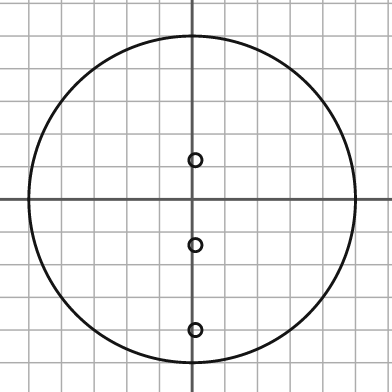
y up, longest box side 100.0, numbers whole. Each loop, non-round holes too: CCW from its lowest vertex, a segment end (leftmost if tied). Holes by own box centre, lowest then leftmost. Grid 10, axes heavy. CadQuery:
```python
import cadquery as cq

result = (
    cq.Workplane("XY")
    .moveTo(0.0, 0.0)
    .circle(50.0)
    .moveTo(1.0, -40.0)
    .circle(2.0)
    .moveTo(1.0, -14.0)
    .circle(2.0)
    .moveTo(1.0, 12.0)
    .circle(2.0)
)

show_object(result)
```